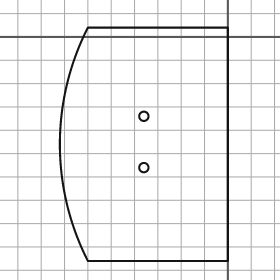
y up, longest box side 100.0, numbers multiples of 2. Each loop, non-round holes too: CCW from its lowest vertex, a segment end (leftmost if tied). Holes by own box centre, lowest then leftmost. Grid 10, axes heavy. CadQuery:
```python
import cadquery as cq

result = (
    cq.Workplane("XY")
    .moveTo(-60.0, -96.0)
    .lineTo(0.0, -96.0)
    .lineTo(0.0, 4.0)
    .lineTo(-60.0, 4.0)
    .threePointArc((-72.0, -46.0), (-60.0, -96.0))
    .close()
    .moveTo(-36.0, -56.0)
    .circle(2.0)
    .moveTo(-36.0, -34.0)
    .circle(2.0)
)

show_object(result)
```